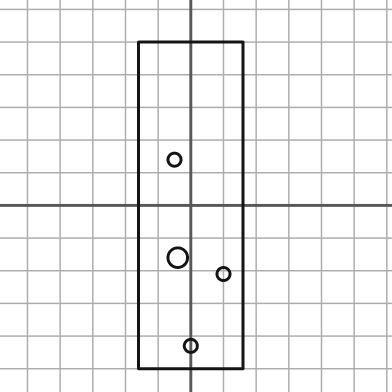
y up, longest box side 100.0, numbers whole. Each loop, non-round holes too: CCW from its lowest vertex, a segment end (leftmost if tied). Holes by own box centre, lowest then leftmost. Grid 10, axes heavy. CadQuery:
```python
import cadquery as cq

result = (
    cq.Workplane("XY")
    .moveTo(-16.0, -50.0)
    .lineTo(16.0, -50.0)
    .lineTo(16.0, 50.0)
    .lineTo(-16.0, 50.0)
    .close()
    .moveTo(0.0, -43.0)
    .circle(2.0)
    .moveTo(10.0, -21.0)
    .circle(2.0)
    .moveTo(-4.0, -16.0)
    .circle(3.0)
    .moveTo(-5.0, 14.0)
    .circle(2.0)
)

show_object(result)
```